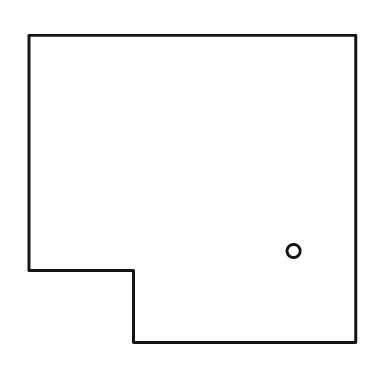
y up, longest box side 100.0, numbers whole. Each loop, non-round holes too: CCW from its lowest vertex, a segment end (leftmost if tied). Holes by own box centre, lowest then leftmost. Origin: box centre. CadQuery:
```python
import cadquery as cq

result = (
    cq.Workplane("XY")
    .moveTo(-18.0, -47.0)
    .lineTo(50.0, -47.0)
    .lineTo(50.0, 47.0)
    .lineTo(-50.0, 47.0)
    .lineTo(-50.0, -25.0)
    .lineTo(-18.0, -25.0)
    .close()
    .moveTo(31.0, -19.0)
    .circle(2.0)
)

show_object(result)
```